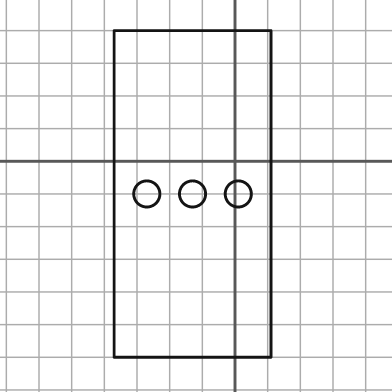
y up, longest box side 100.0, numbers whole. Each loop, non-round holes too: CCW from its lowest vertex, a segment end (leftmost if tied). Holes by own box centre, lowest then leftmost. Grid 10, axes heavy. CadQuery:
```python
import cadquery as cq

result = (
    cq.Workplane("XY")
    .moveTo(-37.0, -60.0)
    .lineTo(11.0, -60.0)
    .lineTo(11.0, 40.0)
    .lineTo(-37.0, 40.0)
    .close()
    .moveTo(-27.0, -10.0)
    .circle(4.0)
    .moveTo(-13.0, -10.0)
    .circle(4.0)
    .moveTo(1.0, -10.0)
    .circle(4.0)
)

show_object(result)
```